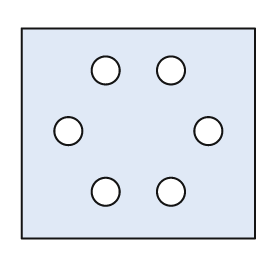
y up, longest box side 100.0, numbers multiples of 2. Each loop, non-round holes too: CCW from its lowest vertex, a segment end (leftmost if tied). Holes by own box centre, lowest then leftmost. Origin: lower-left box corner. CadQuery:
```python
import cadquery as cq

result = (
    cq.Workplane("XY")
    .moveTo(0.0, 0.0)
    .lineTo(100.0, 0.0)
    .lineTo(100.0, 90.0)
    .lineTo(0.0, 90.0)
    .close()
    .moveTo(36.0, 20.0)
    .circle(6.0)
    .moveTo(64.0, 20.0)
    .circle(6.0)
    .moveTo(20.0, 46.0)
    .circle(6.0)
    .moveTo(80.0, 46.0)
    .circle(6.0)
    .moveTo(36.0, 72.0)
    .circle(6.0)
    .moveTo(64.0, 72.0)
    .circle(6.0)
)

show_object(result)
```